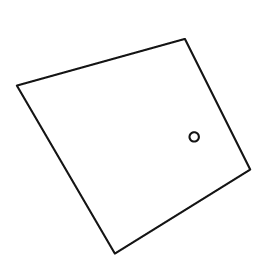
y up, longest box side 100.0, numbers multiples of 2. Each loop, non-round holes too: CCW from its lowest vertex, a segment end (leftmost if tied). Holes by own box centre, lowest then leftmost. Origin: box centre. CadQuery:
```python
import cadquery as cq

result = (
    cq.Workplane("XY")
    .moveTo(-8.0, -46.0)
    .lineTo(50.0, -10.0)
    .lineTo(22.0, 46.0)
    .lineTo(-50.0, 26.0)
    .close()
    .moveTo(26.0, 4.0)
    .circle(2.0)
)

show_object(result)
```